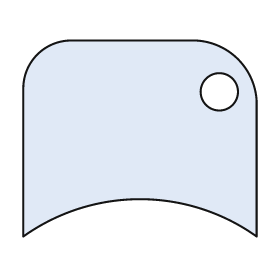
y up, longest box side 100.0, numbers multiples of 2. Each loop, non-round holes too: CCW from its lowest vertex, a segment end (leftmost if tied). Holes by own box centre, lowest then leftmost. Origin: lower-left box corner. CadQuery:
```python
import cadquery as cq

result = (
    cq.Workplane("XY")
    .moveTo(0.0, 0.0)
    .threePointArc((50.0, 16.0), (100.0, 0.0))
    .lineTo(100.0, 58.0)
    .threePointArc((92.0, 76.0), (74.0, 84.0))
    .lineTo(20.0, 84.0)
    .threePointArc((6.0, 78.0), (0.0, 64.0))
    .close()
    .moveTo(84.0, 62.0)
    .circle(8.0)
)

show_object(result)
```